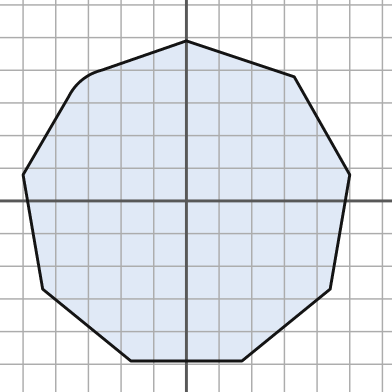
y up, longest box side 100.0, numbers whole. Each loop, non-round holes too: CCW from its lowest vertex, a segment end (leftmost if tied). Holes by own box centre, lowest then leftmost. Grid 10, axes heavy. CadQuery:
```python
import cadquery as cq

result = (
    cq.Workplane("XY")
    .moveTo(-17.0, -49.0)
    .lineTo(17.0, -49.0)
    .lineTo(44.0, -27.0)
    .lineTo(50.0, 8.0)
    .lineTo(33.0, 38.0)
    .lineTo(0.0, 49.0)
    .lineTo(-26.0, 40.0)
    .threePointArc((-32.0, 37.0), (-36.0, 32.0))
    .lineTo(-50.0, 8.0)
    .lineTo(-44.0, -27.0)
    .close()
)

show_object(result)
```